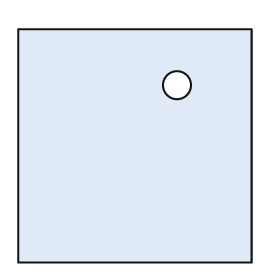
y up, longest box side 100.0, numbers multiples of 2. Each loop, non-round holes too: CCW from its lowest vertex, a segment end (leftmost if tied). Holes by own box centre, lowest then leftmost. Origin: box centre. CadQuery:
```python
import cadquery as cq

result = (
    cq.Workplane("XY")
    .moveTo(-50.0, -50.0)
    .lineTo(50.0, -50.0)
    .lineTo(50.0, 50.0)
    .lineTo(-50.0, 50.0)
    .close()
    .moveTo(18.0, 26.0)
    .circle(6.0)
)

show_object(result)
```